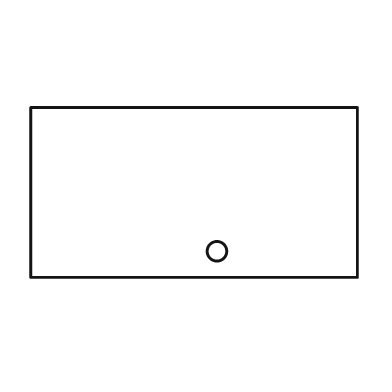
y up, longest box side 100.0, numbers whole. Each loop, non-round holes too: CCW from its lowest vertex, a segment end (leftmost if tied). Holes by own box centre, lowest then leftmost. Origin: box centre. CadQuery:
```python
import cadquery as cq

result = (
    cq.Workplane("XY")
    .moveTo(-50.0, -26.0)
    .lineTo(50.0, -26.0)
    .lineTo(50.0, 26.0)
    .lineTo(-50.0, 26.0)
    .close()
    .moveTo(7.0, -18.0)
    .circle(3.0)
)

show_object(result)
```